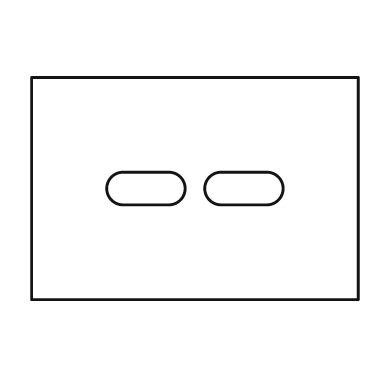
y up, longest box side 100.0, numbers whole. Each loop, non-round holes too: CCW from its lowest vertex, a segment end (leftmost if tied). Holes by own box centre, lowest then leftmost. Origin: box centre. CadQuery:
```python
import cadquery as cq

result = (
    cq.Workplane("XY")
    .moveTo(-50.0, -34.0)
    .lineTo(50.0, -34.0)
    .lineTo(50.0, 34.0)
    .lineTo(-50.0, 34.0)
    .close()
    .moveTo(-22.0, -5.0)
    .lineTo(-8.0, -5.0)
    .threePointArc((-3.0, 0.0), (-8.0, 5.0))
    .lineTo(-22.0, 5.0)
    .threePointArc((-27.0, 0.0), (-22.0, -5.0))
    .close()
    .moveTo(8.0, -5.0)
    .lineTo(22.0, -5.0)
    .threePointArc((27.0, 0.0), (22.0, 5.0))
    .lineTo(8.0, 5.0)
    .threePointArc((3.0, 0.0), (8.0, -5.0))
    .close()
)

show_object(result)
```